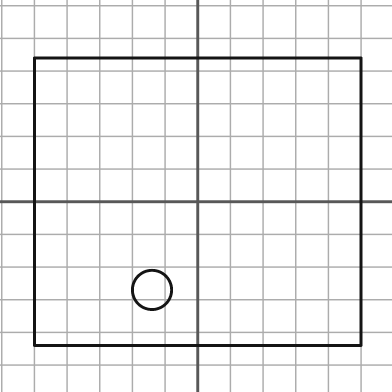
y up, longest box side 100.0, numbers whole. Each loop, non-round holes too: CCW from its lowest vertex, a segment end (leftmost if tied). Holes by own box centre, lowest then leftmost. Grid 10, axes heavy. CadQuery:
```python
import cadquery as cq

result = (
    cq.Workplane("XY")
    .moveTo(-50.0, -44.0)
    .lineTo(50.0, -44.0)
    .lineTo(50.0, 44.0)
    .lineTo(-50.0, 44.0)
    .close()
    .moveTo(-14.0, -27.0)
    .circle(6.0)
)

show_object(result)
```